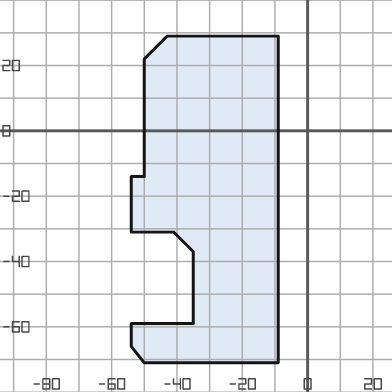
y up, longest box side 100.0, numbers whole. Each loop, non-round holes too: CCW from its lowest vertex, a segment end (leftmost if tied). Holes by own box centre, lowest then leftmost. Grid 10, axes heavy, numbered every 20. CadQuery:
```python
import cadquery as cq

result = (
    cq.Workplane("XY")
    .moveTo(-50.0, -71.0)
    .lineTo(-9.0, -71.0)
    .lineTo(-9.0, 29.0)
    .lineTo(-43.0, 29.0)
    .lineTo(-50.0, 22.0)
    .lineTo(-50.0, -14.0)
    .lineTo(-54.0, -14.0)
    .lineTo(-54.0, -31.0)
    .lineTo(-41.0, -31.0)
    .lineTo(-35.0, -37.0)
    .lineTo(-35.0, -59.0)
    .lineTo(-54.0, -59.0)
    .lineTo(-54.0, -66.0)
    .close()
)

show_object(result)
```